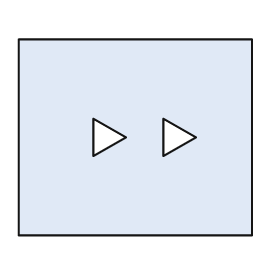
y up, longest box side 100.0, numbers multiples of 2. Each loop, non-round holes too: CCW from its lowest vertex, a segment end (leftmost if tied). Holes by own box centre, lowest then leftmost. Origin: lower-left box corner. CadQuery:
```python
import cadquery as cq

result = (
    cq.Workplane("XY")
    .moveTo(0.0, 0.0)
    .lineTo(100.0, 0.0)
    .lineTo(100.0, 84.0)
    .lineTo(0.0, 84.0)
    .close()
    .moveTo(32.0, 34.0)
    .lineTo(46.0, 42.0)
    .lineTo(32.0, 50.0)
    .close()
    .moveTo(62.0, 34.0)
    .lineTo(76.0, 42.0)
    .lineTo(62.0, 50.0)
    .close()
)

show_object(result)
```